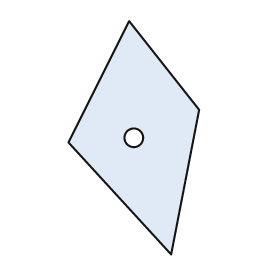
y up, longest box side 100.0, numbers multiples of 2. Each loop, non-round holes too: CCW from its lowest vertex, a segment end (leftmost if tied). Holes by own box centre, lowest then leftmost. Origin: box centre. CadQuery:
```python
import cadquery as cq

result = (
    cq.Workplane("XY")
    .moveTo(16.0, -50.0)
    .lineTo(28.0, 12.0)
    .lineTo(-2.0, 50.0)
    .lineTo(-28.0, -2.0)
    .close()
    .moveTo(0.0, 0.0)
    .circle(4.0)
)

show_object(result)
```